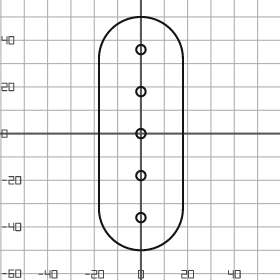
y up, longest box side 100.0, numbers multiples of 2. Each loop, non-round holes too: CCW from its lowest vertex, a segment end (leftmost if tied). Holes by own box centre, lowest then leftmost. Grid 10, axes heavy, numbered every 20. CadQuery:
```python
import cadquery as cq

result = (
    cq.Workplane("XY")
    .moveTo(-18.0, -32.0)
    .threePointArc((0.0, -50.0), (18.0, -32.0))
    .lineTo(18.0, 32.0)
    .threePointArc((0.0, 50.0), (-18.0, 32.0))
    .close()
    .moveTo(0.0, -36.0)
    .circle(2.0)
    .moveTo(0.0, -18.0)
    .circle(2.0)
    .moveTo(0.0, 0.0)
    .circle(2.0)
    .moveTo(0.0, 18.0)
    .circle(2.0)
    .moveTo(0.0, 36.0)
    .circle(2.0)
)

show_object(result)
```